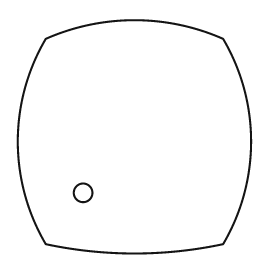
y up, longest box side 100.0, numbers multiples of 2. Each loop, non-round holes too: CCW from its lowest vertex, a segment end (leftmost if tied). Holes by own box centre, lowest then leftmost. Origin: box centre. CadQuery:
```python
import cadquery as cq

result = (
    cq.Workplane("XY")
    .moveTo(-38.0, -46.0)
    .threePointArc((0.0, -50.0), (38.0, -46.0))
    .threePointArc((50.0, -2.0), (38.0, 42.0))
    .threePointArc((0.0, 50.0), (-38.0, 42.0))
    .threePointArc((-50.0, -2.0), (-38.0, -46.0))
    .close()
    .moveTo(-22.0, -24.0)
    .circle(4.0)
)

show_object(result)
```